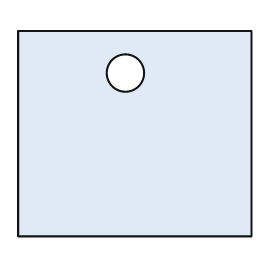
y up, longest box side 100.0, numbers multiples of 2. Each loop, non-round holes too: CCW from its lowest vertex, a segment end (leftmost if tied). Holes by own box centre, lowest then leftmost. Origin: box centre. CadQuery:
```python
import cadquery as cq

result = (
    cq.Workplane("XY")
    .moveTo(-50.0, -44.0)
    .lineTo(50.0, -44.0)
    .lineTo(50.0, 44.0)
    .lineTo(-50.0, 44.0)
    .close()
    .moveTo(-4.0, 26.0)
    .circle(8.0)
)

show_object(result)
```